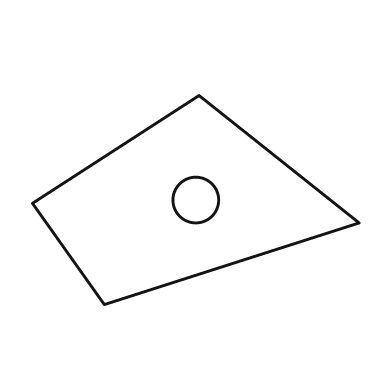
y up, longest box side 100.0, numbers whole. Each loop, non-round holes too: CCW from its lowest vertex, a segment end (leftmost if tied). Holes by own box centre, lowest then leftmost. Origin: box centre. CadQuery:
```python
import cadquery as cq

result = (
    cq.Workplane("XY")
    .moveTo(-28.0, -32.0)
    .lineTo(50.0, -7.0)
    .lineTo(1.0, 32.0)
    .lineTo(-50.0, -1.0)
    .close()
    .moveTo(0.0, 0.0)
    .circle(7.0)
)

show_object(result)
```